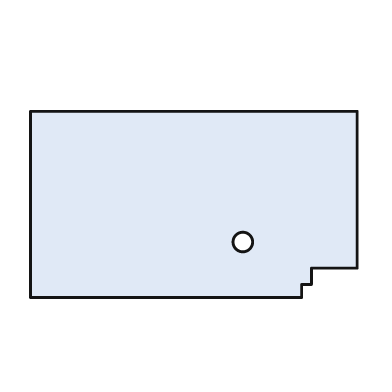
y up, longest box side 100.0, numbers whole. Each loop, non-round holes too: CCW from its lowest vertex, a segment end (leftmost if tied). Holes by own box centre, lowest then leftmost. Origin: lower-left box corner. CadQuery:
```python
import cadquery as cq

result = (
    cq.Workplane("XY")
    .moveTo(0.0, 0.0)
    .lineTo(83.0, 0.0)
    .lineTo(83.0, 4.0)
    .lineTo(86.0, 4.0)
    .lineTo(86.0, 9.0)
    .lineTo(100.0, 9.0)
    .lineTo(100.0, 57.0)
    .lineTo(0.0, 57.0)
    .close()
    .moveTo(65.0, 17.0)
    .circle(3.0)
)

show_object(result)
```